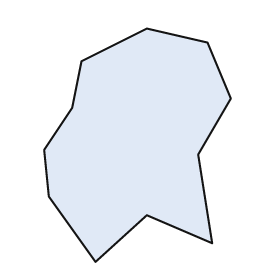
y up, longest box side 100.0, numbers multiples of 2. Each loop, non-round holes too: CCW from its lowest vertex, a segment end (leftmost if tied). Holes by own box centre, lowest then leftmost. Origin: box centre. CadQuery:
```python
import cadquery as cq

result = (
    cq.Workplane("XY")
    .moveTo(-18.0, -50.0)
    .lineTo(4.0, -30.0)
    .lineTo(32.0, -42.0)
    .lineTo(26.0, -4.0)
    .lineTo(40.0, 20.0)
    .lineTo(30.0, 44.0)
    .lineTo(4.0, 50.0)
    .lineTo(-24.0, 36.0)
    .lineTo(-28.0, 16.0)
    .lineTo(-40.0, -2.0)
    .lineTo(-38.0, -22.0)
    .close()
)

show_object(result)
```